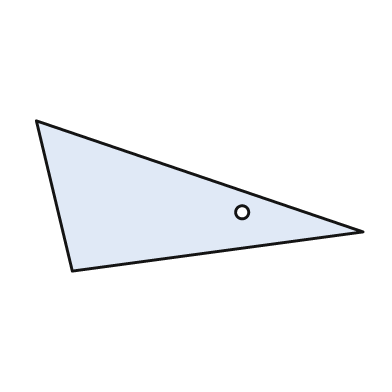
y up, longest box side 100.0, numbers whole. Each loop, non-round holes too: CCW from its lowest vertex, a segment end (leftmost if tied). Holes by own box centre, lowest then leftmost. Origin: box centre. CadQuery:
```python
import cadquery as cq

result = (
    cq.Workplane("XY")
    .moveTo(-39.0, -23.0)
    .lineTo(50.0, -11.0)
    .lineTo(-50.0, 23.0)
    .close()
    .moveTo(13.0, -5.0)
    .circle(2.0)
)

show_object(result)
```